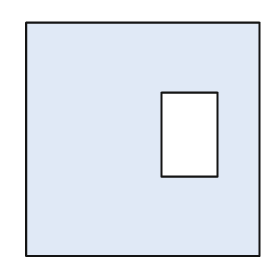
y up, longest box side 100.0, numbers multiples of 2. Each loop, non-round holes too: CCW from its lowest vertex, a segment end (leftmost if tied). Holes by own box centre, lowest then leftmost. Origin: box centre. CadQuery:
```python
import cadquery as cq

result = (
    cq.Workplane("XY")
    .moveTo(-50.0, -50.0)
    .lineTo(50.0, -50.0)
    .lineTo(50.0, 50.0)
    .lineTo(-50.0, 50.0)
    .close()
    .moveTo(8.0, -16.0)
    .lineTo(32.0, -16.0)
    .lineTo(32.0, 20.0)
    .lineTo(8.0, 20.0)
    .close()
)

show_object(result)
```